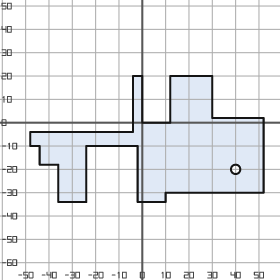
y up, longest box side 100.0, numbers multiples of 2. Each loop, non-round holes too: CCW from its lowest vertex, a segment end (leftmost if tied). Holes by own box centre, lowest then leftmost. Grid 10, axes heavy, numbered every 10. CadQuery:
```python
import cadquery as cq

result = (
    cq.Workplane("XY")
    .moveTo(-36.0, -34.0)
    .lineTo(-24.0, -34.0)
    .lineTo(-24.0, -10.0)
    .lineTo(-2.0, -10.0)
    .lineTo(-2.0, -34.0)
    .lineTo(10.0, -34.0)
    .lineTo(10.0, -30.0)
    .lineTo(52.0, -30.0)
    .lineTo(52.0, 2.0)
    .lineTo(30.0, 2.0)
    .lineTo(30.0, 20.0)
    .lineTo(12.0, 20.0)
    .lineTo(12.0, 0.0)
    .lineTo(0.0, 0.0)
    .lineTo(0.0, 20.0)
    .lineTo(-4.0, 20.0)
    .lineTo(-4.0, -4.0)
    .lineTo(-48.0, -4.0)
    .lineTo(-48.0, -10.0)
    .lineTo(-44.0, -10.0)
    .lineTo(-44.0, -18.0)
    .lineTo(-36.0, -18.0)
    .close()
    .moveTo(40.0, -20.0)
    .circle(2.0)
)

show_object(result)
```